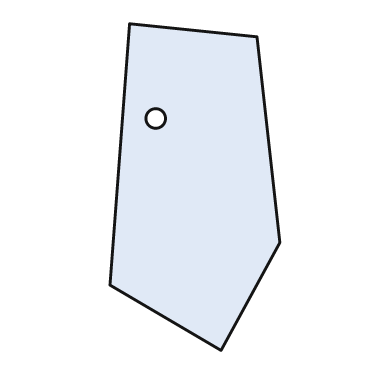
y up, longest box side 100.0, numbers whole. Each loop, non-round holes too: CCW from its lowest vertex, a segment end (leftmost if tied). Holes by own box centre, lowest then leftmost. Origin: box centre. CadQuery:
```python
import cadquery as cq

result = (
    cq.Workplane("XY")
    .moveTo(8.0, -50.0)
    .lineTo(26.0, -17.0)
    .lineTo(19.0, 46.0)
    .lineTo(-20.0, 50.0)
    .lineTo(-26.0, -30.0)
    .close()
    .moveTo(-12.0, 21.0)
    .circle(3.0)
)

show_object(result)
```